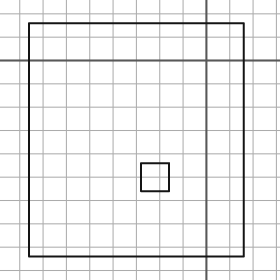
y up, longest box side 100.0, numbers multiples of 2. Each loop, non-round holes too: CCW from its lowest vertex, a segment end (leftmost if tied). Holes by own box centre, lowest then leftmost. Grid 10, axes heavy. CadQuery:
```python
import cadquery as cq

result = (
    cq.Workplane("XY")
    .moveTo(-76.0, -84.0)
    .lineTo(16.0, -84.0)
    .lineTo(16.0, 16.0)
    .lineTo(-76.0, 16.0)
    .close()
    .moveTo(-28.0, -56.0)
    .lineTo(-16.0, -56.0)
    .lineTo(-16.0, -44.0)
    .lineTo(-28.0, -44.0)
    .close()
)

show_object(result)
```